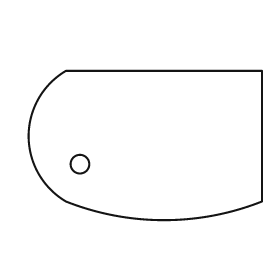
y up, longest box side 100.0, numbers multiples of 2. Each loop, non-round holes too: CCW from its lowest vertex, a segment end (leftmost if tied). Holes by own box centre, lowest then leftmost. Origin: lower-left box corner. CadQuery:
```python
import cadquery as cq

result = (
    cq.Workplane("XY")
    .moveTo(16.0, 8.0)
    .threePointArc((58.0, 0.0), (100.0, 8.0))
    .lineTo(100.0, 64.0)
    .lineTo(16.0, 64.0)
    .threePointArc((0.0, 36.0), (16.0, 8.0))
    .close()
    .moveTo(22.0, 24.0)
    .circle(4.0)
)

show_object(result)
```